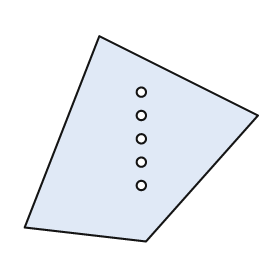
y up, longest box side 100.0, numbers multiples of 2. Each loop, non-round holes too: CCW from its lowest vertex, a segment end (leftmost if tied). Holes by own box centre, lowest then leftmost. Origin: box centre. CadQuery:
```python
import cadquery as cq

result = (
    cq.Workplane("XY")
    .moveTo(2.0, -44.0)
    .lineTo(50.0, 10.0)
    .lineTo(-18.0, 44.0)
    .lineTo(-50.0, -38.0)
    .close()
    .moveTo(0.0, -20.0)
    .circle(2.0)
    .moveTo(0.0, -10.0)
    .circle(2.0)
    .moveTo(0.0, 0.0)
    .circle(2.0)
    .moveTo(0.0, 10.0)
    .circle(2.0)
    .moveTo(0.0, 20.0)
    .circle(2.0)
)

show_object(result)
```